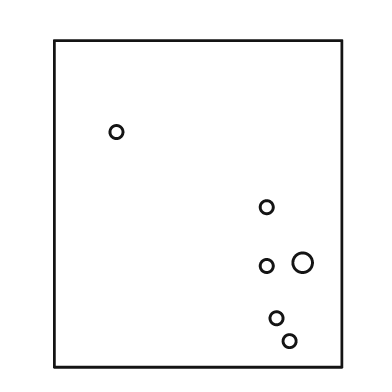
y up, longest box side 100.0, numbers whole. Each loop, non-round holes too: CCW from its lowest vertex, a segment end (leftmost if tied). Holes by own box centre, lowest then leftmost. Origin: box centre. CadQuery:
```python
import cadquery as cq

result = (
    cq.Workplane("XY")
    .moveTo(-44.0, -50.0)
    .lineTo(44.0, -50.0)
    .lineTo(44.0, 50.0)
    .lineTo(-44.0, 50.0)
    .close()
    .moveTo(28.0, -42.0)
    .circle(2.0)
    .moveTo(24.0, -35.0)
    .circle(2.0)
    .moveTo(21.0, -19.0)
    .circle(2.0)
    .moveTo(32.0, -18.0)
    .circle(3.0)
    .moveTo(21.0, -1.0)
    .circle(2.0)
    .moveTo(-25.0, 22.0)
    .circle(2.0)
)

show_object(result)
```